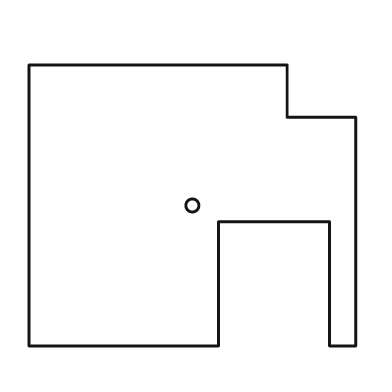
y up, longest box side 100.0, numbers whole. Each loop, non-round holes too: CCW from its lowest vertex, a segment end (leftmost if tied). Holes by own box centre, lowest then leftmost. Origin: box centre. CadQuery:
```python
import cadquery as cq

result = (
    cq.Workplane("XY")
    .moveTo(-50.0, -43.0)
    .lineTo(8.0, -43.0)
    .lineTo(8.0, -5.0)
    .lineTo(42.0, -5.0)
    .lineTo(42.0, -43.0)
    .lineTo(50.0, -43.0)
    .lineTo(50.0, 27.0)
    .lineTo(29.0, 27.0)
    .lineTo(29.0, 43.0)
    .lineTo(-50.0, 43.0)
    .close()
    .moveTo(0.0, 0.0)
    .circle(2.0)
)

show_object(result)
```